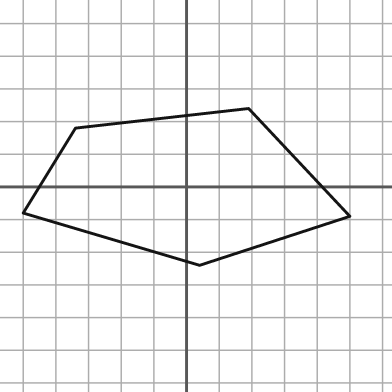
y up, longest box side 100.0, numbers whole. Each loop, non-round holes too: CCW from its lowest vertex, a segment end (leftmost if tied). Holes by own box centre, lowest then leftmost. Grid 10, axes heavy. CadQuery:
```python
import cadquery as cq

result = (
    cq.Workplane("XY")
    .moveTo(4.0, -24.0)
    .lineTo(50.0, -9.0)
    .lineTo(19.0, 24.0)
    .lineTo(-34.0, 18.0)
    .lineTo(-50.0, -8.0)
    .close()
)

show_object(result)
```